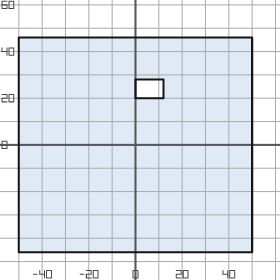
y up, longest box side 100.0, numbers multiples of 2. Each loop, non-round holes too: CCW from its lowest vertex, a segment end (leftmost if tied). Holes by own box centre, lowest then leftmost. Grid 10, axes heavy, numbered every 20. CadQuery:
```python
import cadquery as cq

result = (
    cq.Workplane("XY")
    .moveTo(-50.0, -46.0)
    .lineTo(50.0, -46.0)
    .lineTo(50.0, 46.0)
    .lineTo(-50.0, 46.0)
    .close()
    .moveTo(0.0, 20.0)
    .lineTo(12.0, 20.0)
    .lineTo(12.0, 28.0)
    .lineTo(0.0, 28.0)
    .close()
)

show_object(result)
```